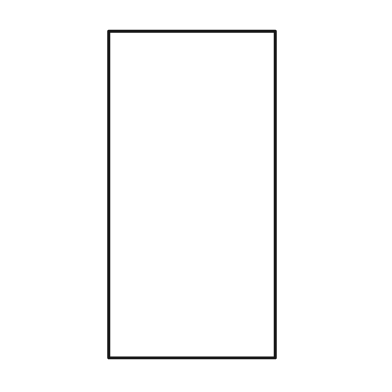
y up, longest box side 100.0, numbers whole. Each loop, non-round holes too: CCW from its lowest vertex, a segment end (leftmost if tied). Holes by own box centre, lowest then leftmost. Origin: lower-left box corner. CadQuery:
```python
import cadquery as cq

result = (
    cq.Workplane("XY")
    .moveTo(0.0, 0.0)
    .lineTo(51.0, 0.0)
    .lineTo(51.0, 100.0)
    .lineTo(0.0, 100.0)
    .close()
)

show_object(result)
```